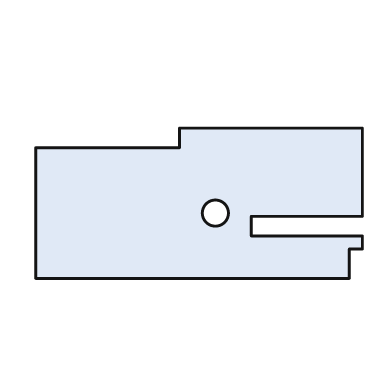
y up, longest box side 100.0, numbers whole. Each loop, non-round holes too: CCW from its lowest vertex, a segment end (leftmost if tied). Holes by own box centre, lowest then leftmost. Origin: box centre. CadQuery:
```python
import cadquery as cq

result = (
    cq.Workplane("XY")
    .moveTo(-50.0, -23.0)
    .lineTo(46.0, -23.0)
    .lineTo(46.0, -14.0)
    .lineTo(50.0, -14.0)
    .lineTo(50.0, -10.0)
    .lineTo(16.0, -10.0)
    .lineTo(16.0, -4.0)
    .lineTo(50.0, -4.0)
    .lineTo(50.0, 23.0)
    .lineTo(-6.0, 23.0)
    .lineTo(-6.0, 17.0)
    .lineTo(-50.0, 17.0)
    .close()
    .moveTo(5.0, -3.0)
    .circle(4.0)
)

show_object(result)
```